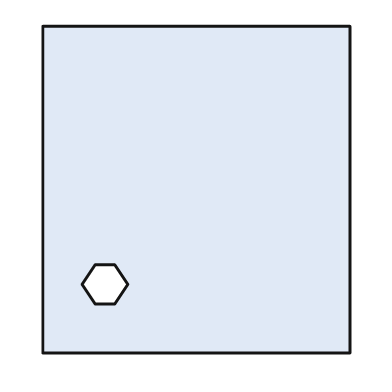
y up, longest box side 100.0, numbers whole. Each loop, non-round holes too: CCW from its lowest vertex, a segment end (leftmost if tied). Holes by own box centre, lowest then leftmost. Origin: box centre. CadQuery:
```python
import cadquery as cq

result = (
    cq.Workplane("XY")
    .moveTo(-47.0, -50.0)
    .lineTo(47.0, -50.0)
    .lineTo(47.0, 50.0)
    .lineTo(-47.0, 50.0)
    .close()
    .moveTo(-31.0, -35.0)
    .lineTo(-25.0, -35.0)
    .lineTo(-21.0, -29.0)
    .lineTo(-25.0, -23.0)
    .lineTo(-31.0, -23.0)
    .lineTo(-35.0, -29.0)
    .close()
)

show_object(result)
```